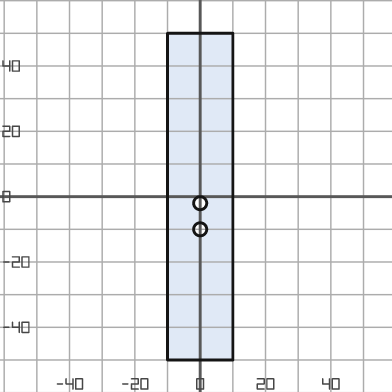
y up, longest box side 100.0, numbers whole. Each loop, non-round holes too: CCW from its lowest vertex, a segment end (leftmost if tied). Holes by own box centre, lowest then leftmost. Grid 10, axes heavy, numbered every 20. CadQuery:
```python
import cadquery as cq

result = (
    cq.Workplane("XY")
    .moveTo(-10.0, -50.0)
    .lineTo(10.0, -50.0)
    .lineTo(10.0, 50.0)
    .lineTo(-10.0, 50.0)
    .close()
    .moveTo(0.0, -10.0)
    .circle(2.0)
    .moveTo(0.0, -2.0)
    .circle(2.0)
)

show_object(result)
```